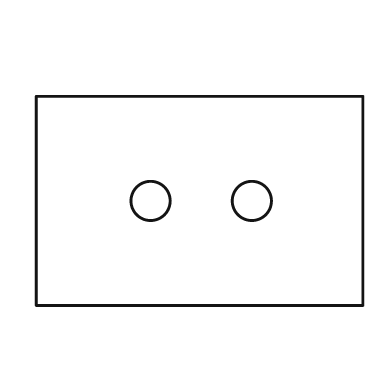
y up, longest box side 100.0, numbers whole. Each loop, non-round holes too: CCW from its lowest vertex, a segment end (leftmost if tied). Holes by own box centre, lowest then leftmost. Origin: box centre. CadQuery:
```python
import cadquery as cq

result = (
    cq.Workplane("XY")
    .moveTo(-50.0, -32.0)
    .lineTo(50.0, -32.0)
    .lineTo(50.0, 32.0)
    .lineTo(-50.0, 32.0)
    .close()
    .moveTo(-15.0, 0.0)
    .circle(6.0)
    .moveTo(16.0, 0.0)
    .circle(6.0)
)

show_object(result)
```